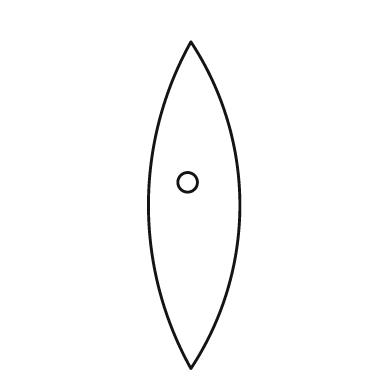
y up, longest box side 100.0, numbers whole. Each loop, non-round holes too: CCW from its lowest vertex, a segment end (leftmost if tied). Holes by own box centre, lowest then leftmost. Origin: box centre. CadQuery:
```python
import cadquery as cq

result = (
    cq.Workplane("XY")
    .moveTo(-1.0, -50.0)
    .threePointArc((14.0, 0.0), (-1.0, 50.0))
    .threePointArc((-14.0, 0.0), (-1.0, -50.0))
    .close()
    .moveTo(-2.0, 7.0)
    .circle(3.0)
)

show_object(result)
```